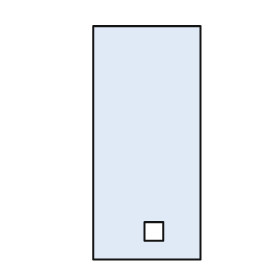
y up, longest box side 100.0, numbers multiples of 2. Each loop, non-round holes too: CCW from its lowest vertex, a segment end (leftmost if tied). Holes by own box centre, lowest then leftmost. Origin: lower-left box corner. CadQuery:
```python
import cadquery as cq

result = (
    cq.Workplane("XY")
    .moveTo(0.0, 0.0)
    .lineTo(46.0, 0.0)
    .lineTo(46.0, 100.0)
    .lineTo(0.0, 100.0)
    .close()
    .moveTo(22.0, 8.0)
    .lineTo(30.0, 8.0)
    .lineTo(30.0, 16.0)
    .lineTo(22.0, 16.0)
    .close()
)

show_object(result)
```